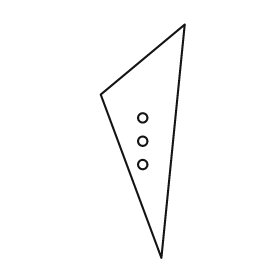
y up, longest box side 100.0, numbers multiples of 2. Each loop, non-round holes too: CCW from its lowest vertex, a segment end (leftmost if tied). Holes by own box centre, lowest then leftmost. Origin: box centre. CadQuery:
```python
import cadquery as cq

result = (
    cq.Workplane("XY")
    .moveTo(8.0, -50.0)
    .lineTo(18.0, 50.0)
    .lineTo(-18.0, 20.0)
    .close()
    .moveTo(0.0, -10.0)
    .circle(2.0)
    .moveTo(0.0, 0.0)
    .circle(2.0)
    .moveTo(0.0, 10.0)
    .circle(2.0)
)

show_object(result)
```